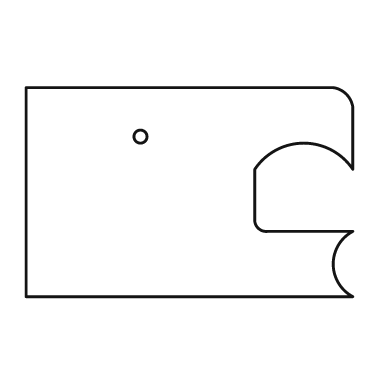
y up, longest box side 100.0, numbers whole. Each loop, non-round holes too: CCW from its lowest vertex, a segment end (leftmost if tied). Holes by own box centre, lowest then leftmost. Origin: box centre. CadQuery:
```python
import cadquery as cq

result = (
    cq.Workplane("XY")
    .moveTo(-50.0, -32.0)
    .lineTo(50.0, -32.0)
    .threePointArc((44.0, -22.0), (50.0, -12.0))
    .lineTo(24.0, -12.0)
    .threePointArc((21.0, -11.0), (20.0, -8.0))
    .lineTo(20.0, 7.0)
    .threePointArc((35.0, 15.0), (50.0, 7.0))
    .lineTo(50.0, 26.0)
    .threePointArc((48.0, 30.0), (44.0, 32.0))
    .lineTo(-50.0, 32.0)
    .close()
    .moveTo(-15.0, 17.0)
    .circle(2.0)
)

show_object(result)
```